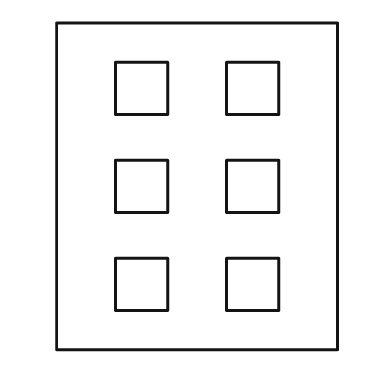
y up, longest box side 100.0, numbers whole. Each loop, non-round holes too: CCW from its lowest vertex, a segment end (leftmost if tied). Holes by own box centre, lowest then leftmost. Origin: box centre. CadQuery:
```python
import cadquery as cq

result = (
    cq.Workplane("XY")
    .moveTo(-43.0, -50.0)
    .lineTo(43.0, -50.0)
    .lineTo(43.0, 50.0)
    .lineTo(-43.0, 50.0)
    .close()
    .moveTo(-25.0, -38.0)
    .lineTo(-9.0, -38.0)
    .lineTo(-9.0, -22.0)
    .lineTo(-25.0, -22.0)
    .close()
    .moveTo(9.0, -38.0)
    .lineTo(25.0, -38.0)
    .lineTo(25.0, -22.0)
    .lineTo(9.0, -22.0)
    .close()
    .moveTo(-25.0, -8.0)
    .lineTo(-9.0, -8.0)
    .lineTo(-9.0, 8.0)
    .lineTo(-25.0, 8.0)
    .close()
    .moveTo(9.0, -8.0)
    .lineTo(25.0, -8.0)
    .lineTo(25.0, 8.0)
    .lineTo(9.0, 8.0)
    .close()
    .moveTo(-25.0, 22.0)
    .lineTo(-9.0, 22.0)
    .lineTo(-9.0, 38.0)
    .lineTo(-25.0, 38.0)
    .close()
    .moveTo(9.0, 22.0)
    .lineTo(25.0, 22.0)
    .lineTo(25.0, 38.0)
    .lineTo(9.0, 38.0)
    .close()
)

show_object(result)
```